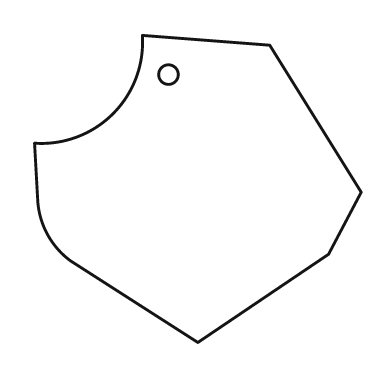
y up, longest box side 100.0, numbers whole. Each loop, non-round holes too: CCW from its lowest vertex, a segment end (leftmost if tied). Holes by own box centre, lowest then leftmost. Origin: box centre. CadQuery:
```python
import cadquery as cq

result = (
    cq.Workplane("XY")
    .moveTo(0.0, -47.0)
    .lineTo(40.0, -20.0)
    .lineTo(50.0, -1.0)
    .lineTo(22.0, 44.0)
    .lineTo(-17.0, 47.0)
    .threePointArc((-26.0, 23.0), (-50.0, 14.0))
    .lineTo(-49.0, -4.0)
    .threePointArc((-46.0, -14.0), (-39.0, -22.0))
    .close()
    .moveTo(-9.0, 35.0)
    .circle(3.0)
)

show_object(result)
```